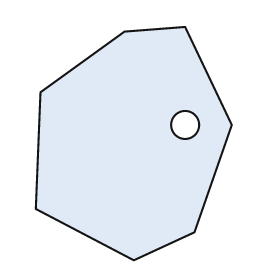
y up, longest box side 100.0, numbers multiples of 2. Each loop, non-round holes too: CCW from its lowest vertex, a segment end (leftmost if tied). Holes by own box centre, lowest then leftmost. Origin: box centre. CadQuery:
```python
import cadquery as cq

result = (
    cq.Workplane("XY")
    .moveTo(0.0, -50.0)
    .lineTo(26.0, -38.0)
    .lineTo(42.0, 8.0)
    .lineTo(22.0, 50.0)
    .lineTo(-4.0, 48.0)
    .lineTo(-40.0, 22.0)
    .lineTo(-42.0, -28.0)
    .close()
    .moveTo(22.0, 8.0)
    .circle(6.0)
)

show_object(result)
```